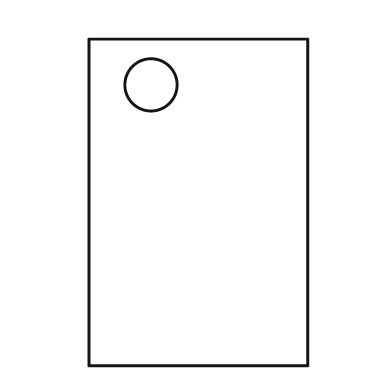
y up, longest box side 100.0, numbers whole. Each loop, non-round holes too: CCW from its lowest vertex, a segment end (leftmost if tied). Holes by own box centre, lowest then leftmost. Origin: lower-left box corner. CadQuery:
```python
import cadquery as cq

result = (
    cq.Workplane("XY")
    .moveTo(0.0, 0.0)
    .lineTo(67.0, 0.0)
    .lineTo(67.0, 100.0)
    .lineTo(0.0, 100.0)
    .close()
    .moveTo(19.0, 86.0)
    .circle(8.0)
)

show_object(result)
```